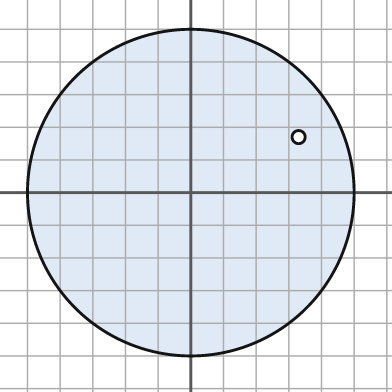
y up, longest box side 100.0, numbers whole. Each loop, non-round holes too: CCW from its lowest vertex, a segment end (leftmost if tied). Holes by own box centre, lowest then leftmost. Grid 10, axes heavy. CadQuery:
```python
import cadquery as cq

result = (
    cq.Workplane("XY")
    .moveTo(0.0, 0.0)
    .circle(50.0)
    .moveTo(33.0, 17.0)
    .circle(2.0)
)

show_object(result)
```